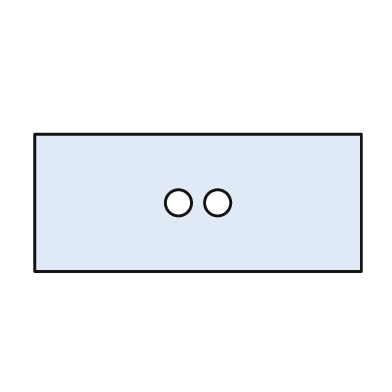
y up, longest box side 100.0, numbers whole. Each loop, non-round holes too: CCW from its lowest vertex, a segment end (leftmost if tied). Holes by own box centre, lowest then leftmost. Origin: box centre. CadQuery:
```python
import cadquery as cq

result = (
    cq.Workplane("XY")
    .moveTo(-50.0, -21.0)
    .lineTo(50.0, -21.0)
    .lineTo(50.0, 21.0)
    .lineTo(-50.0, 21.0)
    .close()
    .moveTo(-6.0, 0.0)
    .circle(4.0)
    .moveTo(6.0, 0.0)
    .circle(4.0)
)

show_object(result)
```